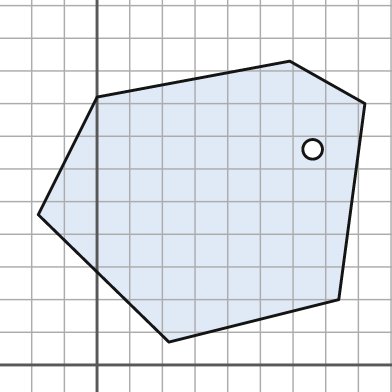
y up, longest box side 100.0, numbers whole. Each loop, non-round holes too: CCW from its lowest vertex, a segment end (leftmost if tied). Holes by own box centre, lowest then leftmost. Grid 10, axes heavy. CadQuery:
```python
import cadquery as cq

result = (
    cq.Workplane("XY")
    .moveTo(22.0, 7.0)
    .lineTo(74.0, 20.0)
    .lineTo(82.0, 80.0)
    .lineTo(59.0, 93.0)
    .lineTo(0.0, 82.0)
    .lineTo(-18.0, 46.0)
    .close()
    .moveTo(66.0, 66.0)
    .circle(3.0)
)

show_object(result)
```